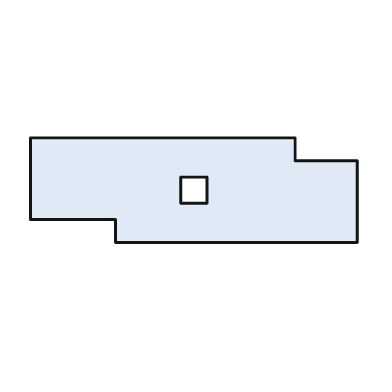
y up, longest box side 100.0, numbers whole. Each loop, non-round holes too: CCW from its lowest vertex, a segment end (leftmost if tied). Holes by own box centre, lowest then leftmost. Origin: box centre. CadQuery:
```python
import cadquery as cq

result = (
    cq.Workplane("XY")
    .moveTo(-24.0, -16.0)
    .lineTo(50.0, -16.0)
    .lineTo(50.0, 9.0)
    .lineTo(31.0, 9.0)
    .lineTo(31.0, 16.0)
    .lineTo(-50.0, 16.0)
    .lineTo(-50.0, -9.0)
    .lineTo(-24.0, -9.0)
    .close()
    .moveTo(-4.0, -4.0)
    .lineTo(4.0, -4.0)
    .lineTo(4.0, 4.0)
    .lineTo(-4.0, 4.0)
    .close()
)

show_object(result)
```